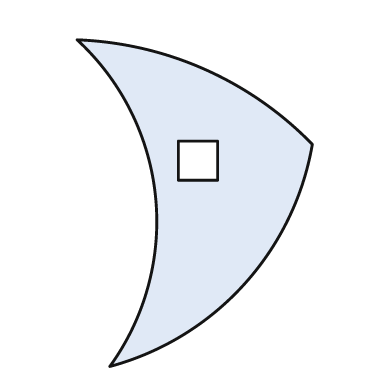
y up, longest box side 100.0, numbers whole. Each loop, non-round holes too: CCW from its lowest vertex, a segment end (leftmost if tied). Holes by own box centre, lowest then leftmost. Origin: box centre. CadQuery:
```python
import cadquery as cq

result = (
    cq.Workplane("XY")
    .moveTo(-26.0, -50.0)
    .threePointArc((15.0, -25.0), (36.0, 18.0))
    .threePointArc((3.0, 41.0), (-36.0, 50.0))
    .threePointArc((-12.0, 2.0), (-26.0, -50.0))
    .close()
    .moveTo(-5.0, 7.0)
    .lineTo(7.0, 7.0)
    .lineTo(7.0, 19.0)
    .lineTo(-5.0, 19.0)
    .close()
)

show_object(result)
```